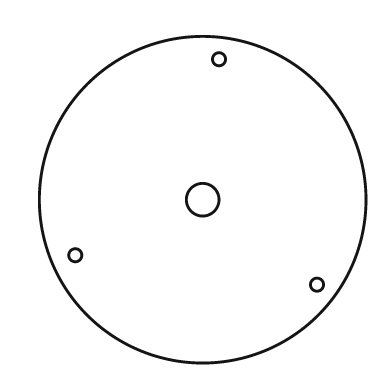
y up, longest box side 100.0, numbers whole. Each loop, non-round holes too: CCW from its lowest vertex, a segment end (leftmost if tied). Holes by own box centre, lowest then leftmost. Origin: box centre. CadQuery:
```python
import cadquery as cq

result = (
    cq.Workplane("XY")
    .moveTo(0.0, 0.0)
    .circle(50.0)
    .moveTo(35.0, -26.0)
    .circle(2.0)
    .moveTo(-39.0, -17.0)
    .circle(2.0)
    .moveTo(0.0, 0.0)
    .circle(5.0)
    .moveTo(5.0, 43.0)
    .circle(2.0)
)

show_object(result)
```